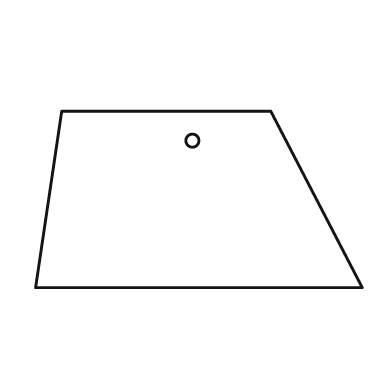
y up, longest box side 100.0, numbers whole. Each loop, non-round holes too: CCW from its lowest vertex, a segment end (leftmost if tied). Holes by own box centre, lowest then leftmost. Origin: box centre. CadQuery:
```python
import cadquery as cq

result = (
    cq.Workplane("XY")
    .moveTo(-50.0, -27.0)
    .lineTo(50.0, -27.0)
    .lineTo(22.0, 27.0)
    .lineTo(-42.0, 27.0)
    .close()
    .moveTo(-2.0, 18.0)
    .circle(2.0)
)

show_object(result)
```